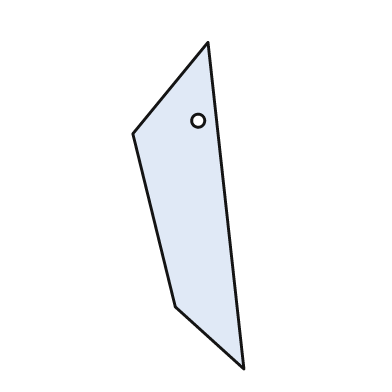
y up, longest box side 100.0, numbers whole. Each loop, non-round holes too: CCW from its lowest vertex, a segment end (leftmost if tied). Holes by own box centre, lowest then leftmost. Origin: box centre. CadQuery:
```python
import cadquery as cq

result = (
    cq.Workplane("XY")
    .moveTo(17.0, -50.0)
    .lineTo(6.0, 50.0)
    .lineTo(-17.0, 22.0)
    .lineTo(-4.0, -31.0)
    .close()
    .moveTo(3.0, 26.0)
    .circle(2.0)
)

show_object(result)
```